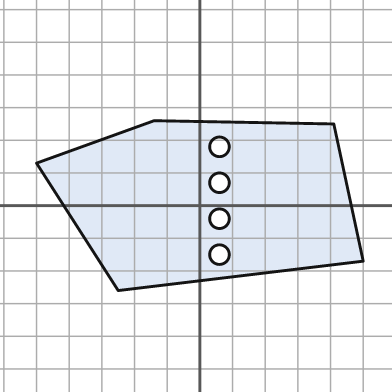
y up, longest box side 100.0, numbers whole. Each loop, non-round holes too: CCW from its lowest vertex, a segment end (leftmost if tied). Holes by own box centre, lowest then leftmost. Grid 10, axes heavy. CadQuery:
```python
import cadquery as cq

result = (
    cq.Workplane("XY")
    .moveTo(-25.0, -26.0)
    .lineTo(50.0, -17.0)
    .lineTo(41.0, 25.0)
    .lineTo(-14.0, 26.0)
    .lineTo(-50.0, 13.0)
    .close()
    .moveTo(6.0, -15.0)
    .circle(3.0)
    .moveTo(6.0, -4.0)
    .circle(3.0)
    .moveTo(6.0, 7.0)
    .circle(3.0)
    .moveTo(6.0, 18.0)
    .circle(3.0)
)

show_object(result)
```